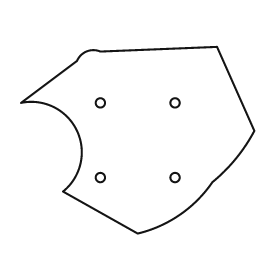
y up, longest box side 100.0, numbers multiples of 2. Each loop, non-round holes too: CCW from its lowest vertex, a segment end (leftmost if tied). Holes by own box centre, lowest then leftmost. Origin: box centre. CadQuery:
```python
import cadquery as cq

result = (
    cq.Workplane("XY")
    .moveTo(0.0, -40.0)
    .threePointArc((18.0, -32.0), (32.0, -18.0))
    .threePointArc((42.0, -8.0), (50.0, 4.0))
    .lineTo(34.0, 40.0)
    .lineTo(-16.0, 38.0)
    .threePointArc((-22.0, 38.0), (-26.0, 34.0))
    .lineTo(-50.0, 16.0)
    .threePointArc((-26.0, 4.0), (-32.0, -22.0))
    .close()
    .moveTo(-16.0, -16.0)
    .circle(2.0)
    .moveTo(16.0, -16.0)
    .circle(2.0)
    .moveTo(-16.0, 16.0)
    .circle(2.0)
    .moveTo(16.0, 16.0)
    .circle(2.0)
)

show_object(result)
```